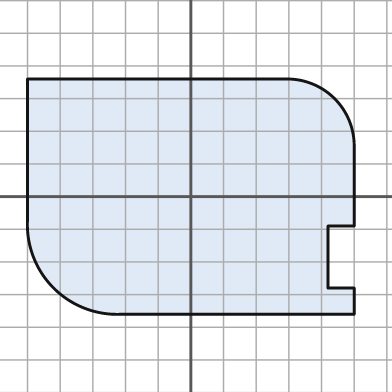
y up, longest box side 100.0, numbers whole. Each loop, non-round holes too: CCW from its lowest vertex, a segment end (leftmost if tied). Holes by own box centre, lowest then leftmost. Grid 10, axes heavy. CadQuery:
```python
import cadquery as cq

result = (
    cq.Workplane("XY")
    .moveTo(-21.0, -36.0)
    .lineTo(50.0, -36.0)
    .lineTo(50.0, -28.0)
    .lineTo(42.0, -28.0)
    .lineTo(42.0, -9.0)
    .lineTo(50.0, -9.0)
    .lineTo(50.0, 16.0)
    .threePointArc((44.0, 30.0), (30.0, 36.0))
    .lineTo(-50.0, 36.0)
    .lineTo(-50.0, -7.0)
    .threePointArc((-42.0, -28.0), (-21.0, -36.0))
    .close()
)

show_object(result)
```